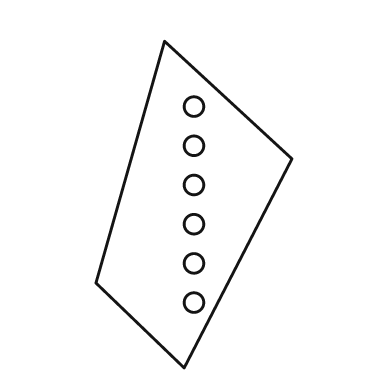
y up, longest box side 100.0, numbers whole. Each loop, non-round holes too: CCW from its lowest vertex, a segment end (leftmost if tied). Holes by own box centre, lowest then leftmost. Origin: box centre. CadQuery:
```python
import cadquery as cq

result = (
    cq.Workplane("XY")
    .moveTo(-3.0, -50.0)
    .lineTo(30.0, 14.0)
    .lineTo(-9.0, 50.0)
    .lineTo(-30.0, -24.0)
    .close()
    .moveTo(0.0, -30.0)
    .circle(3.0)
    .moveTo(0.0, -18.0)
    .circle(3.0)
    .moveTo(0.0, -6.0)
    .circle(3.0)
    .moveTo(0.0, 6.0)
    .circle(3.0)
    .moveTo(0.0, 18.0)
    .circle(3.0)
    .moveTo(0.0, 30.0)
    .circle(3.0)
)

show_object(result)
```